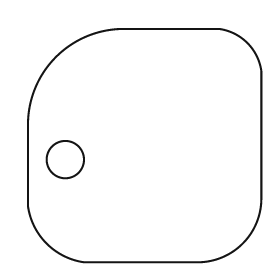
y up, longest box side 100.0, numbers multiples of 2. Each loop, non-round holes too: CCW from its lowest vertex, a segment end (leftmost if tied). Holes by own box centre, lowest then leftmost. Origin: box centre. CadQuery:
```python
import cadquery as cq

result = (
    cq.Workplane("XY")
    .moveTo(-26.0, -50.0)
    .lineTo(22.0, -50.0)
    .threePointArc((42.0, -42.0), (50.0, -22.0))
    .lineTo(50.0, 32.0)
    .threePointArc((44.0, 44.0), (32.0, 50.0))
    .lineTo(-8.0, 50.0)
    .threePointArc((-38.0, 38.0), (-50.0, 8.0))
    .lineTo(-50.0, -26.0)
    .threePointArc((-42.0, -42.0), (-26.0, -50.0))
    .close()
    .moveTo(-34.0, -6.0)
    .circle(8.0)
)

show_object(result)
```